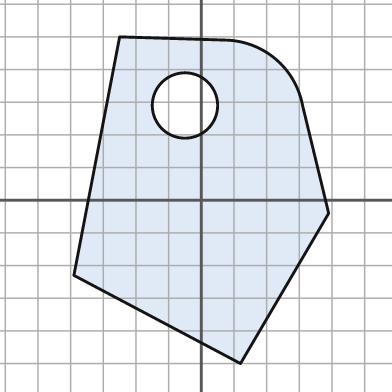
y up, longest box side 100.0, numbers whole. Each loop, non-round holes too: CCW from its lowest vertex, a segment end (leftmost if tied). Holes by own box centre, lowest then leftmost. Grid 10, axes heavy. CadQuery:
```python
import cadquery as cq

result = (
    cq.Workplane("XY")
    .moveTo(12.0, -50.0)
    .lineTo(39.0, -4.0)
    .lineTo(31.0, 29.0)
    .threePointArc((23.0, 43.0), (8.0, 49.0))
    .lineTo(-25.0, 50.0)
    .lineTo(-39.0, -23.0)
    .close()
    .moveTo(-5.0, 29.0)
    .circle(10.0)
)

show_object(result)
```